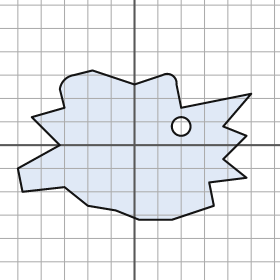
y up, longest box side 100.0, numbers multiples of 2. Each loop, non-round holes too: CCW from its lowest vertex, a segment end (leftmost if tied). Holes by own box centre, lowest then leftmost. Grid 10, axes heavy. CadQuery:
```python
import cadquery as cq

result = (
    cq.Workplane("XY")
    .moveTo(2.0, -32.0)
    .lineTo(16.0, -32.0)
    .lineTo(34.0, -26.0)
    .lineTo(32.0, -16.0)
    .lineTo(48.0, -14.0)
    .lineTo(38.0, -6.0)
    .lineTo(48.0, 4.0)
    .lineTo(38.0, 8.0)
    .lineTo(50.0, 22.0)
    .lineTo(20.0, 16.0)
    .lineTo(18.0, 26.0)
    .threePointArc((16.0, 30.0), (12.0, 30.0))
    .lineTo(0.0, 26.0)
    .lineTo(-18.0, 32.0)
    .lineTo(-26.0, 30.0)
    .threePointArc((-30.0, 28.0), (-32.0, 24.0))
    .lineTo(-30.0, 16.0)
    .lineTo(-44.0, 12.0)
    .lineTo(-32.0, 0.0)
    .lineTo(-50.0, -10.0)
    .lineTo(-48.0, -20.0)
    .lineTo(-30.0, -18.0)
    .lineTo(-20.0, -26.0)
    .lineTo(-8.0, -28.0)
    .close()
    .moveTo(20.0, 8.0)
    .circle(4.0)
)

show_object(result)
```